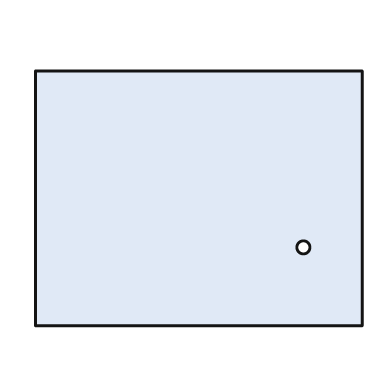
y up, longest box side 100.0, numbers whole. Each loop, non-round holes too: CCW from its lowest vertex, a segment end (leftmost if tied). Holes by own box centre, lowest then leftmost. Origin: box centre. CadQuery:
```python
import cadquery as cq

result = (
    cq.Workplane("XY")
    .moveTo(-50.0, -39.0)
    .lineTo(50.0, -39.0)
    .lineTo(50.0, 39.0)
    .lineTo(-50.0, 39.0)
    .close()
    .moveTo(32.0, -15.0)
    .circle(2.0)
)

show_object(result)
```